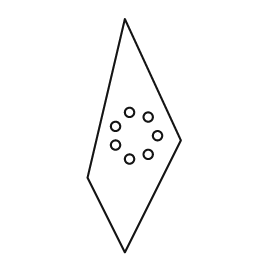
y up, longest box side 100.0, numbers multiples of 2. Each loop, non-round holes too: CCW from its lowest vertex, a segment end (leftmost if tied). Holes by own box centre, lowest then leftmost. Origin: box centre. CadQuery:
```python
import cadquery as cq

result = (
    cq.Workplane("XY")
    .moveTo(-4.0, -50.0)
    .lineTo(20.0, -2.0)
    .lineTo(-4.0, 50.0)
    .lineTo(-20.0, -18.0)
    .close()
    .moveTo(-2.0, -10.0)
    .circle(2.0)
    .moveTo(6.0, -8.0)
    .circle(2.0)
    .moveTo(-8.0, -4.0)
    .circle(2.0)
    .moveTo(10.0, 0.0)
    .circle(2.0)
    .moveTo(-8.0, 4.0)
    .circle(2.0)
    .moveTo(6.0, 8.0)
    .circle(2.0)
    .moveTo(-2.0, 10.0)
    .circle(2.0)
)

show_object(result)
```